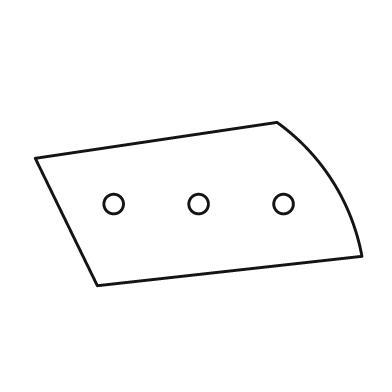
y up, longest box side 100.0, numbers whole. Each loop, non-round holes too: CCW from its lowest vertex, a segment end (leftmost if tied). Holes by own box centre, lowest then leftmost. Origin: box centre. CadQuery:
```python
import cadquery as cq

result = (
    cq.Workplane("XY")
    .moveTo(-31.0, -25.0)
    .lineTo(50.0, -16.0)
    .threePointArc((41.0, 7.0), (24.0, 25.0))
    .lineTo(-50.0, 14.0)
    .close()
    .moveTo(-26.0, 0.0)
    .circle(3.0)
    .moveTo(0.0, 0.0)
    .circle(3.0)
    .moveTo(26.0, 0.0)
    .circle(3.0)
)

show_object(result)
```